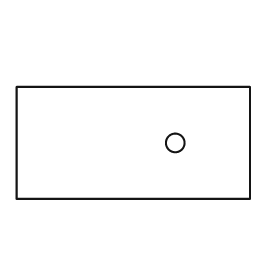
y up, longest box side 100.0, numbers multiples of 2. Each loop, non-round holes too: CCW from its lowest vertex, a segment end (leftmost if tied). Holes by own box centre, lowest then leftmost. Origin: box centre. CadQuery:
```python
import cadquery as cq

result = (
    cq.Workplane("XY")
    .moveTo(-50.0, -24.0)
    .lineTo(50.0, -24.0)
    .lineTo(50.0, 24.0)
    .lineTo(-50.0, 24.0)
    .close()
    .moveTo(18.0, 0.0)
    .circle(4.0)
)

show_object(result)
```